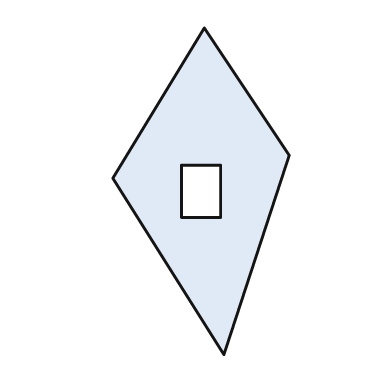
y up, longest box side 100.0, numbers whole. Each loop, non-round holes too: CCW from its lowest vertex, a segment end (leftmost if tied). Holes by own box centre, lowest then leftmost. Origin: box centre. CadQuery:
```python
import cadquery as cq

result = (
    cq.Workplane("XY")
    .moveTo(7.0, -50.0)
    .lineTo(27.0, 11.0)
    .lineTo(1.0, 50.0)
    .lineTo(-27.0, 4.0)
    .close()
    .moveTo(-6.0, -8.0)
    .lineTo(6.0, -8.0)
    .lineTo(6.0, 8.0)
    .lineTo(-6.0, 8.0)
    .close()
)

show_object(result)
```